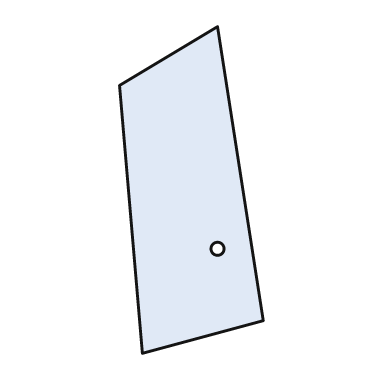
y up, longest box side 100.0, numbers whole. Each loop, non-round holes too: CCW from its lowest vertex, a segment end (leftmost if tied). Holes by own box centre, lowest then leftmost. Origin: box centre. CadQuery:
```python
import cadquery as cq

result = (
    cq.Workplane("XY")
    .moveTo(-15.0, -50.0)
    .lineTo(22.0, -40.0)
    .lineTo(8.0, 50.0)
    .lineTo(-22.0, 32.0)
    .close()
    .moveTo(8.0, -18.0)
    .circle(2.0)
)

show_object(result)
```